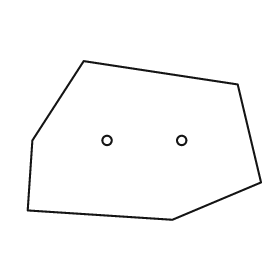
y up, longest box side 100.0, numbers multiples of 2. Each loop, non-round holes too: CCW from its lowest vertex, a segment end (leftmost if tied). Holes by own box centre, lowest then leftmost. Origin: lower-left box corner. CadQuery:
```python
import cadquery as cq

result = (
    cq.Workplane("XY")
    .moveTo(62.0, 0.0)
    .lineTo(100.0, 16.0)
    .lineTo(90.0, 58.0)
    .lineTo(24.0, 68.0)
    .lineTo(2.0, 34.0)
    .lineTo(0.0, 4.0)
    .close()
    .moveTo(34.0, 34.0)
    .circle(2.0)
    .moveTo(66.0, 34.0)
    .circle(2.0)
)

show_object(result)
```